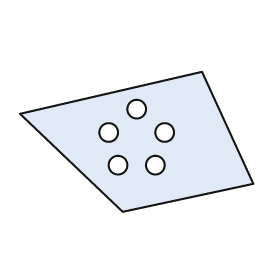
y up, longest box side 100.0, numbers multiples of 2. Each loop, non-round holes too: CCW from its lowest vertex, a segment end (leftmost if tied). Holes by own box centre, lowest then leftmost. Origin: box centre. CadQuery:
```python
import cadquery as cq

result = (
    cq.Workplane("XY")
    .moveTo(-6.0, -30.0)
    .lineTo(50.0, -18.0)
    .lineTo(28.0, 30.0)
    .lineTo(-50.0, 12.0)
    .close()
    .moveTo(-8.0, -10.0)
    .circle(4.0)
    .moveTo(8.0, -10.0)
    .circle(4.0)
    .moveTo(-12.0, 4.0)
    .circle(4.0)
    .moveTo(12.0, 4.0)
    .circle(4.0)
    .moveTo(0.0, 14.0)
    .circle(4.0)
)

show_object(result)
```